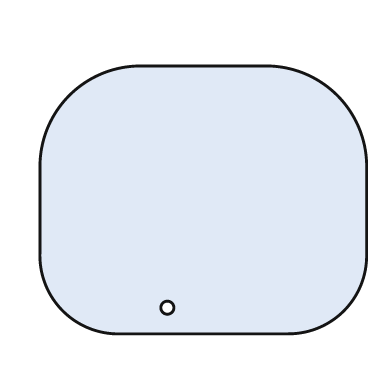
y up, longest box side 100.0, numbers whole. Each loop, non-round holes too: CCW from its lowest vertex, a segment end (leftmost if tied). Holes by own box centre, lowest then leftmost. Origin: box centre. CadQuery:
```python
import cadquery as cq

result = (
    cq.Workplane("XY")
    .moveTo(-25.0, -41.0)
    .lineTo(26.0, -41.0)
    .threePointArc((43.0, -34.0), (50.0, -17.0))
    .lineTo(50.0, 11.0)
    .threePointArc((41.0, 32.0), (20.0, 41.0))
    .lineTo(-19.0, 41.0)
    .threePointArc((-41.0, 32.0), (-50.0, 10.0))
    .lineTo(-50.0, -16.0)
    .threePointArc((-43.0, -34.0), (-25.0, -41.0))
    .close()
    .moveTo(-11.0, -33.0)
    .circle(2.0)
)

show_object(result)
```